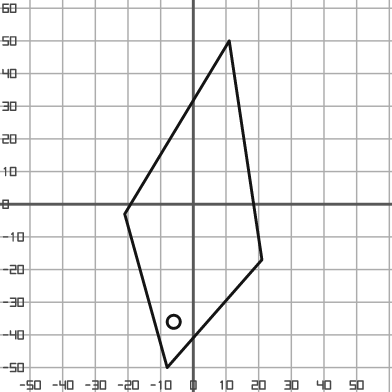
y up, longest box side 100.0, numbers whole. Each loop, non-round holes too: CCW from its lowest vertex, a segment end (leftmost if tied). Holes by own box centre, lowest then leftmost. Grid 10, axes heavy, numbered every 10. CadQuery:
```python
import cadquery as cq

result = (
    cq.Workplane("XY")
    .moveTo(-8.0, -50.0)
    .lineTo(21.0, -17.0)
    .lineTo(11.0, 50.0)
    .lineTo(-21.0, -3.0)
    .close()
    .moveTo(-6.0, -36.0)
    .circle(2.0)
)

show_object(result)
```